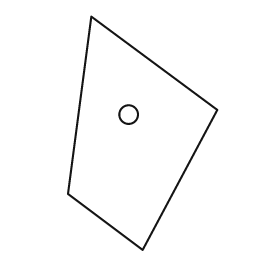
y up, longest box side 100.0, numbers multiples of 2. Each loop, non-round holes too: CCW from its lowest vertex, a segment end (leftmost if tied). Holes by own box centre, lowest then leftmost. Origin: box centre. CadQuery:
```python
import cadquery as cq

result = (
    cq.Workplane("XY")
    .moveTo(0.0, -50.0)
    .lineTo(32.0, 10.0)
    .lineTo(-22.0, 50.0)
    .lineTo(-32.0, -26.0)
    .close()
    .moveTo(-6.0, 8.0)
    .circle(4.0)
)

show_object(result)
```